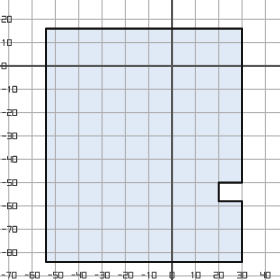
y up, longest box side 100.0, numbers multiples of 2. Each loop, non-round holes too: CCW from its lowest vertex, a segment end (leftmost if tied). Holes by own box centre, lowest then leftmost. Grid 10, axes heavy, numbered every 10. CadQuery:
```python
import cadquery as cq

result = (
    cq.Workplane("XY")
    .moveTo(-54.0, -84.0)
    .lineTo(30.0, -84.0)
    .lineTo(30.0, -58.0)
    .lineTo(20.0, -58.0)
    .lineTo(20.0, -50.0)
    .lineTo(30.0, -50.0)
    .lineTo(30.0, 16.0)
    .lineTo(-54.0, 16.0)
    .close()
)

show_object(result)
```